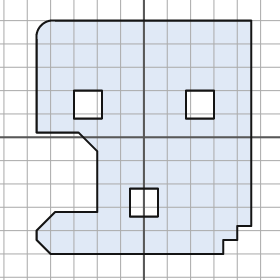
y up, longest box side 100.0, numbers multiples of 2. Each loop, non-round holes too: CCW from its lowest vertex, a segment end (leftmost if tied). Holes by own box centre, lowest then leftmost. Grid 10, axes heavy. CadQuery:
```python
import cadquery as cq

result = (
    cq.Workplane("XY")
    .moveTo(-40.0, -50.0)
    .lineTo(34.0, -50.0)
    .lineTo(34.0, -44.0)
    .lineTo(40.0, -44.0)
    .lineTo(40.0, -38.0)
    .lineTo(46.0, -38.0)
    .lineTo(46.0, 50.0)
    .lineTo(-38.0, 50.0)
    .threePointArc((-44.0, 48.0), (-46.0, 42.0))
    .lineTo(-46.0, 2.0)
    .lineTo(-28.0, 2.0)
    .lineTo(-20.0, -6.0)
    .lineTo(-20.0, -32.0)
    .lineTo(-38.0, -32.0)
    .lineTo(-46.0, -40.0)
    .lineTo(-46.0, -44.0)
    .close()
    .moveTo(-6.0, -34.0)
    .lineTo(6.0, -34.0)
    .lineTo(6.0, -22.0)
    .lineTo(-6.0, -22.0)
    .close()
    .moveTo(-30.0, 8.0)
    .lineTo(-18.0, 8.0)
    .lineTo(-18.0, 20.0)
    .lineTo(-30.0, 20.0)
    .close()
    .moveTo(18.0, 8.0)
    .lineTo(30.0, 8.0)
    .lineTo(30.0, 20.0)
    .lineTo(18.0, 20.0)
    .close()
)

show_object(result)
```